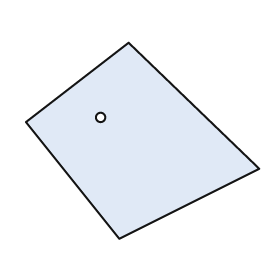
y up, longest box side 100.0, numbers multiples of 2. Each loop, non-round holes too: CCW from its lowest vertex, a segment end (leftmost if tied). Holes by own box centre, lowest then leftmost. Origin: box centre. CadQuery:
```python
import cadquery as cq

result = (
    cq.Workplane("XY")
    .moveTo(-10.0, -42.0)
    .lineTo(50.0, -12.0)
    .lineTo(-6.0, 42.0)
    .lineTo(-50.0, 8.0)
    .close()
    .moveTo(-18.0, 10.0)
    .circle(2.0)
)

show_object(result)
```